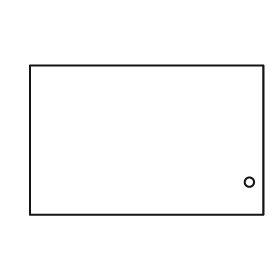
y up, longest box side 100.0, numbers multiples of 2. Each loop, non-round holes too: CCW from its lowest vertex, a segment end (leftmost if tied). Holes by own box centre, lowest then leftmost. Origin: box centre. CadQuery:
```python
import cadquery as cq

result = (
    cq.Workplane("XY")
    .moveTo(-50.0, -32.0)
    .lineTo(50.0, -32.0)
    .lineTo(50.0, 32.0)
    .lineTo(-50.0, 32.0)
    .close()
    .moveTo(44.0, -18.0)
    .circle(2.0)
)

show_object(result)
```